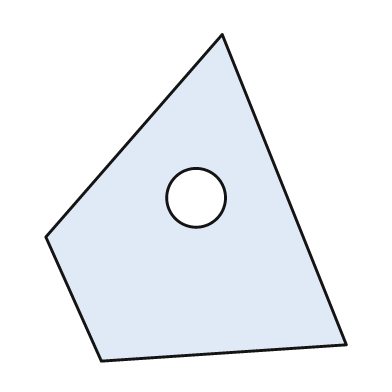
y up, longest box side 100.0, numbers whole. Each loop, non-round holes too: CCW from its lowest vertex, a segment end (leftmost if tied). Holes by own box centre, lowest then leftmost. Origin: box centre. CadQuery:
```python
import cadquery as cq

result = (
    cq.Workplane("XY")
    .moveTo(-29.0, -50.0)
    .lineTo(46.0, -45.0)
    .lineTo(8.0, 50.0)
    .lineTo(-46.0, -12.0)
    .close()
    .moveTo(0.0, 0.0)
    .circle(9.0)
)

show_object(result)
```